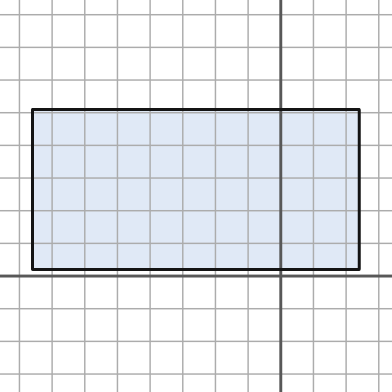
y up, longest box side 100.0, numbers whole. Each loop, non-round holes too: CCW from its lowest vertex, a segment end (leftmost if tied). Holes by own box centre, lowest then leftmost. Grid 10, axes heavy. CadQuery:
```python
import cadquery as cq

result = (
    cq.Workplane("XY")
    .moveTo(-76.0, 2.0)
    .lineTo(24.0, 2.0)
    .lineTo(24.0, 51.0)
    .lineTo(-76.0, 51.0)
    .close()
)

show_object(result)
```